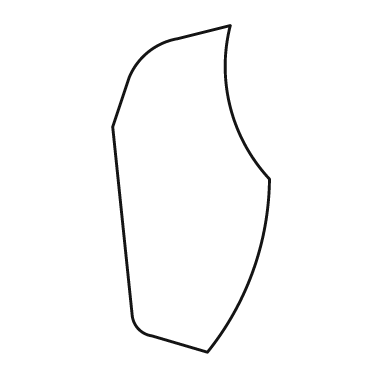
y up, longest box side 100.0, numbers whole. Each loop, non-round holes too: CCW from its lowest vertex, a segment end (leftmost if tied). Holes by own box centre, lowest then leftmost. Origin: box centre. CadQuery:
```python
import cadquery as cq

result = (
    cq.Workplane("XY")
    .moveTo(5.0, -50.0)
    .threePointArc((19.0, -25.0), (24.0, 3.0))
    .threePointArc((12.0, 25.0), (12.0, 50.0))
    .lineTo(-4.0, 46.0)
    .threePointArc((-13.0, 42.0), (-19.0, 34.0))
    .lineTo(-24.0, 19.0)
    .lineTo(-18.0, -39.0)
    .threePointArc((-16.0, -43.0), (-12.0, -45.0))
    .close()
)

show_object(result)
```